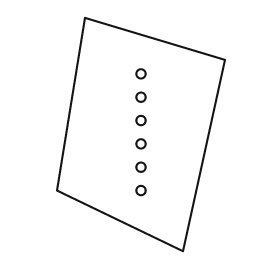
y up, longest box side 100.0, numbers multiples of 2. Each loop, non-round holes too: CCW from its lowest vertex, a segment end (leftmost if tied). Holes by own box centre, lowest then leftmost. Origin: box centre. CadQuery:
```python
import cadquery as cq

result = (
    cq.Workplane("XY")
    .moveTo(18.0, -50.0)
    .lineTo(36.0, 32.0)
    .lineTo(-24.0, 50.0)
    .lineTo(-36.0, -24.0)
    .close()
    .moveTo(0.0, -24.0)
    .circle(2.0)
    .moveTo(0.0, -14.0)
    .circle(2.0)
    .moveTo(0.0, -4.0)
    .circle(2.0)
    .moveTo(0.0, 6.0)
    .circle(2.0)
    .moveTo(0.0, 16.0)
    .circle(2.0)
    .moveTo(0.0, 26.0)
    .circle(2.0)
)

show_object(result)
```